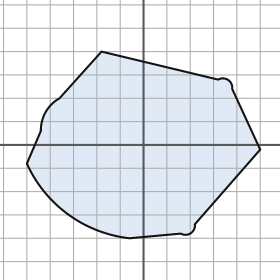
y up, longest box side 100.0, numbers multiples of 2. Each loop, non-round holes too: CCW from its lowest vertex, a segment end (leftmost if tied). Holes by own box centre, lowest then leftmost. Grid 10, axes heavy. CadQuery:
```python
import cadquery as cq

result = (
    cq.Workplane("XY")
    .moveTo(-6.0, -40.0)
    .lineTo(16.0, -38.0)
    .threePointArc((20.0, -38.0), (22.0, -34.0))
    .lineTo(50.0, -2.0)
    .lineTo(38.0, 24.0)
    .threePointArc((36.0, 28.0), (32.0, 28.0))
    .lineTo(-18.0, 40.0)
    .lineTo(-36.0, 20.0)
    .threePointArc((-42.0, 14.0), (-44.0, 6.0))
    .lineTo(-50.0, -8.0)
    .threePointArc((-32.0, -30.0), (-6.0, -40.0))
    .close()
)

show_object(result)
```